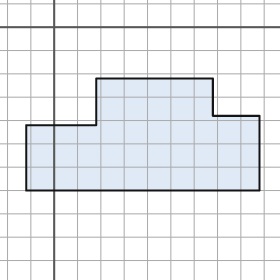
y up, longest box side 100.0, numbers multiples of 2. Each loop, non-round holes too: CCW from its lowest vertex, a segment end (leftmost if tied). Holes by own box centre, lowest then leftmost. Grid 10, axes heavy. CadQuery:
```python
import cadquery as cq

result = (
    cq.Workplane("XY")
    .moveTo(-12.0, -70.0)
    .lineTo(88.0, -70.0)
    .lineTo(88.0, -38.0)
    .lineTo(68.0, -38.0)
    .lineTo(68.0, -22.0)
    .lineTo(18.0, -22.0)
    .lineTo(18.0, -42.0)
    .lineTo(-12.0, -42.0)
    .close()
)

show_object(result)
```